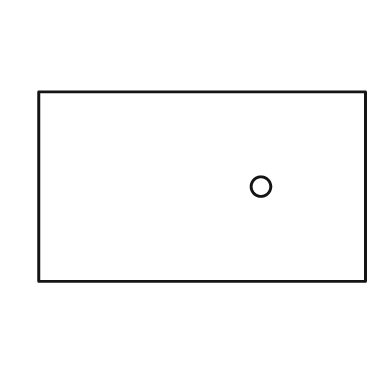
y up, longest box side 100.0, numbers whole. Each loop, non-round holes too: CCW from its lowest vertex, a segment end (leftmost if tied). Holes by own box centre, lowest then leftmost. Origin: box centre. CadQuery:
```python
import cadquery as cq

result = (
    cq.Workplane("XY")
    .moveTo(-50.0, -29.0)
    .lineTo(50.0, -29.0)
    .lineTo(50.0, 29.0)
    .lineTo(-50.0, 29.0)
    .close()
    .moveTo(18.0, 0.0)
    .circle(3.0)
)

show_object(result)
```